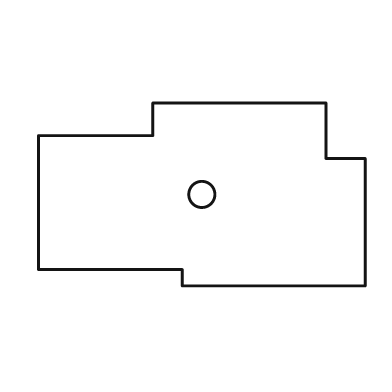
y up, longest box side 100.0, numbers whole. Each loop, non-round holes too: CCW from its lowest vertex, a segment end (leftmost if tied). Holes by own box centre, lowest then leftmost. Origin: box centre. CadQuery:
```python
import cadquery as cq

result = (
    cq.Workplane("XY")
    .moveTo(-6.0, -28.0)
    .lineTo(50.0, -28.0)
    .lineTo(50.0, 11.0)
    .lineTo(38.0, 11.0)
    .lineTo(38.0, 28.0)
    .lineTo(-15.0, 28.0)
    .lineTo(-15.0, 18.0)
    .lineTo(-50.0, 18.0)
    .lineTo(-50.0, -23.0)
    .lineTo(-6.0, -23.0)
    .close()
    .moveTo(0.0, 0.0)
    .circle(4.0)
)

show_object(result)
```